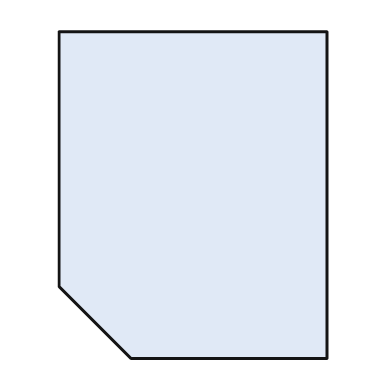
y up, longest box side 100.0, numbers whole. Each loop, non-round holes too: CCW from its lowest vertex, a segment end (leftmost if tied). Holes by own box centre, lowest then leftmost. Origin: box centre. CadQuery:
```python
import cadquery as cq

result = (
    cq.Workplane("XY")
    .moveTo(-19.0, -50.0)
    .lineTo(41.0, -50.0)
    .lineTo(41.0, 50.0)
    .lineTo(-41.0, 50.0)
    .lineTo(-41.0, -28.0)
    .close()
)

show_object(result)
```